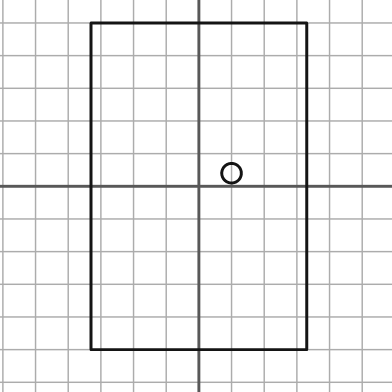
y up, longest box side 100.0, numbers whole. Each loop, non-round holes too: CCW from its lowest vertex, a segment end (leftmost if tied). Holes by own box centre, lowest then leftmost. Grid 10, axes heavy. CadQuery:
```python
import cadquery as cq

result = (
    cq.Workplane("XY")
    .moveTo(-33.0, -50.0)
    .lineTo(33.0, -50.0)
    .lineTo(33.0, 50.0)
    .lineTo(-33.0, 50.0)
    .close()
    .moveTo(10.0, 4.0)
    .circle(3.0)
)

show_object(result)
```